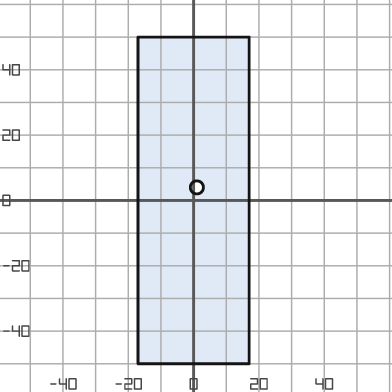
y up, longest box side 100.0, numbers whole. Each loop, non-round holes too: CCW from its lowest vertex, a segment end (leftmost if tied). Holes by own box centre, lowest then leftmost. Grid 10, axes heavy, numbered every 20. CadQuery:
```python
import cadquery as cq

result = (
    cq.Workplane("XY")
    .moveTo(-17.0, -50.0)
    .lineTo(17.0, -50.0)
    .lineTo(17.0, 50.0)
    .lineTo(-17.0, 50.0)
    .close()
    .moveTo(1.0, 4.0)
    .circle(2.0)
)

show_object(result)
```